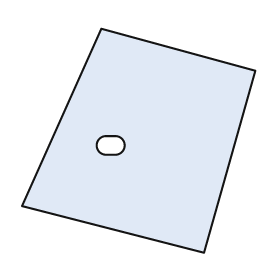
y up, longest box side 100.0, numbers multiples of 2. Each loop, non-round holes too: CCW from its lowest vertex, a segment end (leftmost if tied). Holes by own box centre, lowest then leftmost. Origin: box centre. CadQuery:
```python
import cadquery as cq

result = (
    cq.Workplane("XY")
    .moveTo(28.0, -48.0)
    .lineTo(50.0, 30.0)
    .lineTo(-16.0, 48.0)
    .lineTo(-50.0, -28.0)
    .close()
    .moveTo(-14.0, -6.0)
    .lineTo(-10.0, -6.0)
    .threePointArc((-6.0, -2.0), (-10.0, 2.0))
    .lineTo(-14.0, 2.0)
    .threePointArc((-18.0, -2.0), (-14.0, -6.0))
    .close()
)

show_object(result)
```